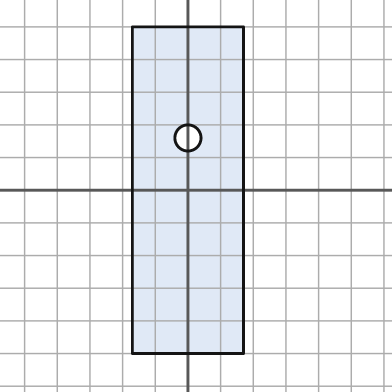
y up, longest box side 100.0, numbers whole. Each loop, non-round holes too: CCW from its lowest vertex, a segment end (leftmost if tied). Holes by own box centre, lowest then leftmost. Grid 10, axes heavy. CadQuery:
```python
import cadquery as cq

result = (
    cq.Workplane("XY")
    .moveTo(-17.0, -50.0)
    .lineTo(17.0, -50.0)
    .lineTo(17.0, 50.0)
    .lineTo(-17.0, 50.0)
    .close()
    .moveTo(0.0, 16.0)
    .circle(4.0)
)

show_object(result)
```